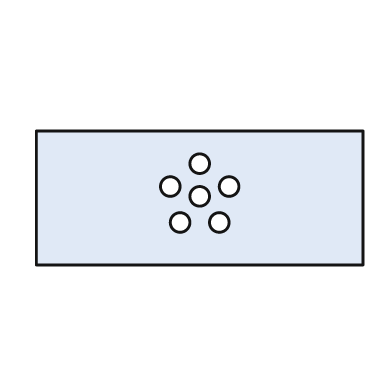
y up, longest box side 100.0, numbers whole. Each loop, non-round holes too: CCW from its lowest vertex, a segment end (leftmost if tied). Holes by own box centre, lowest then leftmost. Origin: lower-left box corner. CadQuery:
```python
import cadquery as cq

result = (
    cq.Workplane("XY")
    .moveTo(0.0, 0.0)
    .lineTo(100.0, 0.0)
    .lineTo(100.0, 41.0)
    .lineTo(0.0, 41.0)
    .close()
    .moveTo(44.0, 13.0)
    .circle(3.0)
    .moveTo(56.0, 13.0)
    .circle(3.0)
    .moveTo(50.0, 21.0)
    .circle(3.0)
    .moveTo(41.0, 24.0)
    .circle(3.0)
    .moveTo(59.0, 24.0)
    .circle(3.0)
    .moveTo(50.0, 31.0)
    .circle(3.0)
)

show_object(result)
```